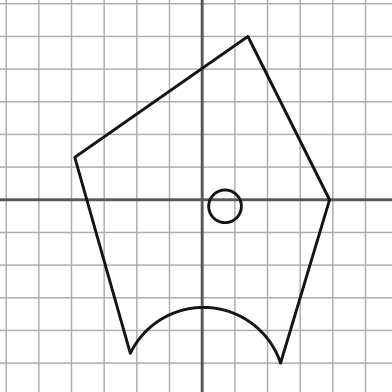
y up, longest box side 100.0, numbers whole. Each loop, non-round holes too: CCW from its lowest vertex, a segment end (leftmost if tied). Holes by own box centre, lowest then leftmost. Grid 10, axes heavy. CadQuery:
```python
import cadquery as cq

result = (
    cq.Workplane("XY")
    .moveTo(24.0, -50.0)
    .lineTo(39.0, 0.0)
    .lineTo(14.0, 50.0)
    .lineTo(-39.0, 13.0)
    .lineTo(-22.0, -47.0)
    .threePointArc((2.0, -33.0), (24.0, -50.0))
    .close()
    .moveTo(7.0, -2.0)
    .circle(5.0)
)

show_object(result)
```